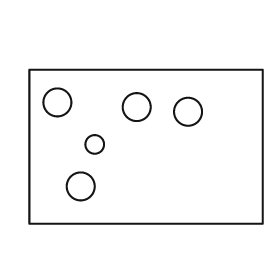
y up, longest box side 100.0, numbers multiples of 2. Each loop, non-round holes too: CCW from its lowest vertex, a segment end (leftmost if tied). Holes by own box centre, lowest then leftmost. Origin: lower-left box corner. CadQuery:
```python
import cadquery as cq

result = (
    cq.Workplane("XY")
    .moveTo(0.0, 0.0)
    .lineTo(100.0, 0.0)
    .lineTo(100.0, 66.0)
    .lineTo(0.0, 66.0)
    .close()
    .moveTo(22.0, 16.0)
    .circle(6.0)
    .moveTo(28.0, 34.0)
    .circle(4.0)
    .moveTo(68.0, 48.0)
    .circle(6.0)
    .moveTo(46.0, 50.0)
    .circle(6.0)
    .moveTo(12.0, 52.0)
    .circle(6.0)
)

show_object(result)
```